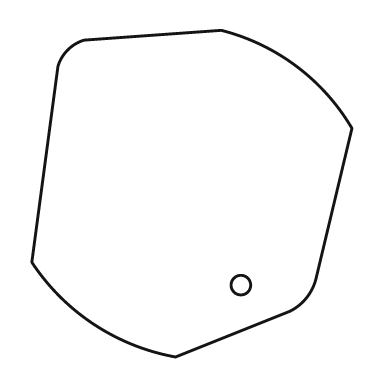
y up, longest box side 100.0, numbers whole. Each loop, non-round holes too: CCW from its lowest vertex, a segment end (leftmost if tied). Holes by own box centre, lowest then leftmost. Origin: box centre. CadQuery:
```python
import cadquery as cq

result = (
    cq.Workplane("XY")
    .moveTo(-5.0, -50.0)
    .lineTo(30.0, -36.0)
    .threePointArc((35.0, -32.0), (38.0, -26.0))
    .lineTo(49.0, 20.0)
    .threePointArc((32.0, 39.0), (9.0, 50.0))
    .lineTo(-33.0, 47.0)
    .threePointArc((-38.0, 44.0), (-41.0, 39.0))
    .lineTo(-49.0, -21.0)
    .threePointArc((-30.0, -40.0), (-5.0, -50.0))
    .close()
    .moveTo(15.0, -28.0)
    .circle(3.0)
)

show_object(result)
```